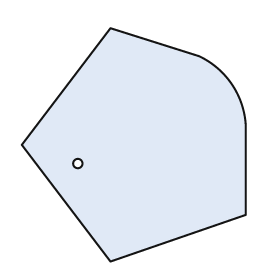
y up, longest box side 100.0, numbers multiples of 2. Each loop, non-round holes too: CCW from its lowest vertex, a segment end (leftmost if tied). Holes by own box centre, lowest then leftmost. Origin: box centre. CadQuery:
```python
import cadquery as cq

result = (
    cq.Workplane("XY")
    .moveTo(-10.0, -50.0)
    .lineTo(48.0, -30.0)
    .lineTo(48.0, 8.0)
    .threePointArc((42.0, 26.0), (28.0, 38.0))
    .lineTo(-10.0, 50.0)
    .lineTo(-48.0, 0.0)
    .close()
    .moveTo(-24.0, -8.0)
    .circle(2.0)
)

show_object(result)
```